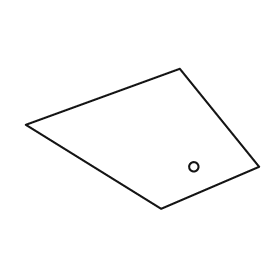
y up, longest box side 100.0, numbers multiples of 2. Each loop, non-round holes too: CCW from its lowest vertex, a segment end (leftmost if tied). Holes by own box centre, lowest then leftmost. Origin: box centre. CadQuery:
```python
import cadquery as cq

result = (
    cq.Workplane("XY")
    .moveTo(8.0, -30.0)
    .lineTo(50.0, -12.0)
    .lineTo(16.0, 30.0)
    .lineTo(-50.0, 6.0)
    .close()
    .moveTo(22.0, -12.0)
    .circle(2.0)
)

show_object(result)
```